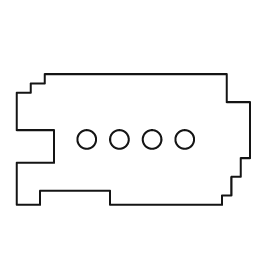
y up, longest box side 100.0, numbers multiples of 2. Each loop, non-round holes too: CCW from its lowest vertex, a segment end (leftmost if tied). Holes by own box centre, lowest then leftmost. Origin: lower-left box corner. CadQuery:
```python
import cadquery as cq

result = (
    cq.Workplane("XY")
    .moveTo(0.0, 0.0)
    .lineTo(10.0, 0.0)
    .lineTo(10.0, 6.0)
    .lineTo(40.0, 6.0)
    .lineTo(40.0, 0.0)
    .lineTo(88.0, 0.0)
    .lineTo(88.0, 4.0)
    .lineTo(92.0, 4.0)
    .lineTo(92.0, 12.0)
    .lineTo(96.0, 12.0)
    .lineTo(96.0, 20.0)
    .lineTo(100.0, 20.0)
    .lineTo(100.0, 44.0)
    .lineTo(90.0, 44.0)
    .lineTo(90.0, 56.0)
    .lineTo(12.0, 56.0)
    .lineTo(12.0, 52.0)
    .lineTo(6.0, 52.0)
    .lineTo(6.0, 48.0)
    .lineTo(0.0, 48.0)
    .lineTo(0.0, 32.0)
    .lineTo(16.0, 32.0)
    .lineTo(16.0, 18.0)
    .lineTo(0.0, 18.0)
    .close()
    .moveTo(30.0, 28.0)
    .circle(4.0)
    .moveTo(44.0, 28.0)
    .circle(4.0)
    .moveTo(58.0, 28.0)
    .circle(4.0)
    .moveTo(72.0, 28.0)
    .circle(4.0)
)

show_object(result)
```